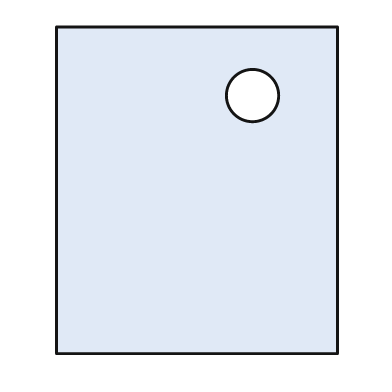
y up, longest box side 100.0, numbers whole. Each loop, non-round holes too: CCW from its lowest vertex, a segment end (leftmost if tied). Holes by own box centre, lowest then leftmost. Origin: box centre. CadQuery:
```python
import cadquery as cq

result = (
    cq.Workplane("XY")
    .moveTo(-43.0, -50.0)
    .lineTo(43.0, -50.0)
    .lineTo(43.0, 50.0)
    .lineTo(-43.0, 50.0)
    .close()
    .moveTo(17.0, 29.0)
    .circle(8.0)
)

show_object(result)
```